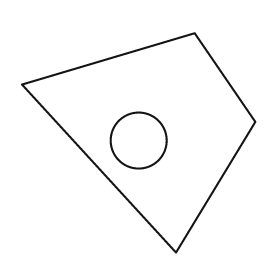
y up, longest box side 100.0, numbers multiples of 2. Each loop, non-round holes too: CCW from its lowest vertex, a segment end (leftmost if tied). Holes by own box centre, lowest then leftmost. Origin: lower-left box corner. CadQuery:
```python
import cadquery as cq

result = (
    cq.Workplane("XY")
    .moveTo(66.0, 0.0)
    .lineTo(100.0, 56.0)
    .lineTo(74.0, 94.0)
    .lineTo(0.0, 72.0)
    .close()
    .moveTo(50.0, 48.0)
    .circle(12.0)
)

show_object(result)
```